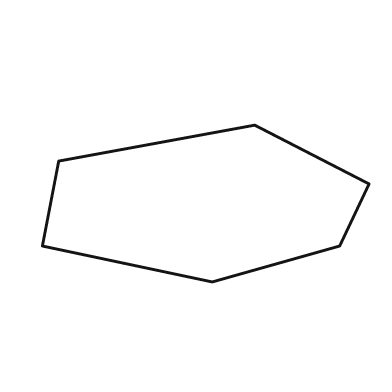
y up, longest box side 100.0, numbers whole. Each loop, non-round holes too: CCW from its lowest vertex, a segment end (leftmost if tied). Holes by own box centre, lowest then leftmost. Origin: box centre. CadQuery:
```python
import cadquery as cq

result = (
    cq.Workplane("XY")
    .moveTo(2.0, -24.0)
    .lineTo(41.0, -13.0)
    .lineTo(50.0, 6.0)
    .lineTo(15.0, 24.0)
    .lineTo(-45.0, 13.0)
    .lineTo(-50.0, -13.0)
    .close()
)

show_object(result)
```